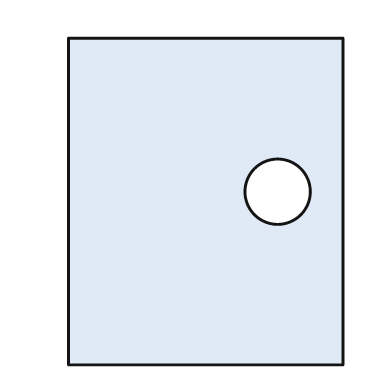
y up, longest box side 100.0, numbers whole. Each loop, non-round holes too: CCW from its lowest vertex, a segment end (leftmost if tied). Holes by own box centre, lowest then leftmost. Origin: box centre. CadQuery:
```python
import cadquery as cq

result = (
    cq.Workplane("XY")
    .moveTo(-42.0, -50.0)
    .lineTo(42.0, -50.0)
    .lineTo(42.0, 50.0)
    .lineTo(-42.0, 50.0)
    .close()
    .moveTo(22.0, 3.0)
    .circle(10.0)
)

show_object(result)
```